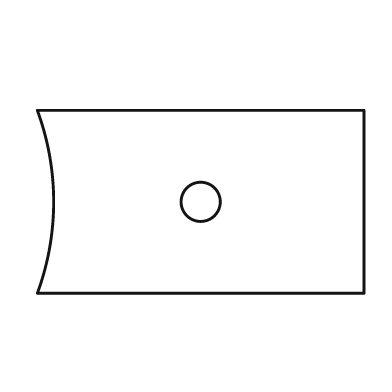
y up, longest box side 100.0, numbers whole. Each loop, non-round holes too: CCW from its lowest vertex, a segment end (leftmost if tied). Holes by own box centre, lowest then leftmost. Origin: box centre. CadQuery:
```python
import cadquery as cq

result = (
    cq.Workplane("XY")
    .moveTo(-50.0, -28.0)
    .lineTo(50.0, -28.0)
    .lineTo(50.0, 28.0)
    .lineTo(-50.0, 28.0)
    .threePointArc((-45.0, 0.0), (-50.0, -28.0))
    .close()
    .moveTo(0.0, 0.0)
    .circle(6.0)
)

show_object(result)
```